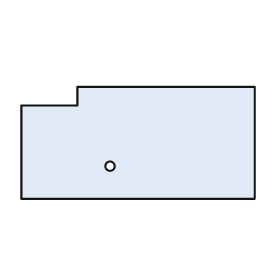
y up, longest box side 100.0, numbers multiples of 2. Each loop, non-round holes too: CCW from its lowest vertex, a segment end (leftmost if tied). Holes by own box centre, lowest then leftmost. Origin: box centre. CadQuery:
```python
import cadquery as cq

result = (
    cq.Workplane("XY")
    .moveTo(-50.0, -24.0)
    .lineTo(50.0, -24.0)
    .lineTo(50.0, 24.0)
    .lineTo(-26.0, 24.0)
    .lineTo(-26.0, 16.0)
    .lineTo(-50.0, 16.0)
    .close()
    .moveTo(-12.0, -10.0)
    .circle(2.0)
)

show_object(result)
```